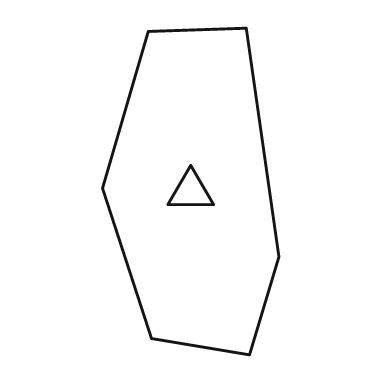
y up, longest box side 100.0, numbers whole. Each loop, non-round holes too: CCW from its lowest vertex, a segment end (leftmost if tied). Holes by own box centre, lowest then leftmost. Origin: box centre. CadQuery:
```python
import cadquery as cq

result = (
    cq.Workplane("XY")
    .moveTo(18.0, -50.0)
    .lineTo(27.0, -20.0)
    .lineTo(17.0, 50.0)
    .lineTo(-13.0, 49.0)
    .lineTo(-27.0, 1.0)
    .lineTo(-12.0, -45.0)
    .close()
    .moveTo(-7.0, -4.0)
    .lineTo(7.0, -4.0)
    .lineTo(0.0, 8.0)
    .close()
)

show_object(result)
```